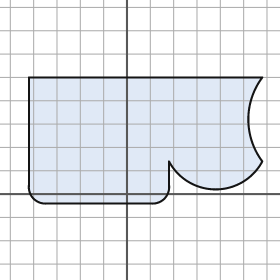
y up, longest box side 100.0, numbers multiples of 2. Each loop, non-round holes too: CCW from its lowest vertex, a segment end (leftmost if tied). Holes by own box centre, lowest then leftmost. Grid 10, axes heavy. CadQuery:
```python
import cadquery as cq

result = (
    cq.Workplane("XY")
    .moveTo(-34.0, -4.0)
    .lineTo(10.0, -4.0)
    .threePointArc((16.0, -2.0), (18.0, 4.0))
    .lineTo(18.0, 14.0)
    .threePointArc((38.0, 2.0), (58.0, 14.0))
    .threePointArc((52.0, 32.0), (58.0, 50.0))
    .lineTo(-42.0, 50.0)
    .lineTo(-42.0, 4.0)
    .threePointArc((-40.0, -2.0), (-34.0, -4.0))
    .close()
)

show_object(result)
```